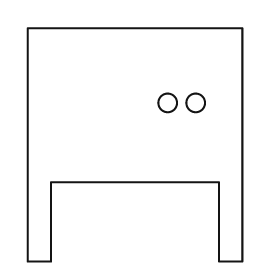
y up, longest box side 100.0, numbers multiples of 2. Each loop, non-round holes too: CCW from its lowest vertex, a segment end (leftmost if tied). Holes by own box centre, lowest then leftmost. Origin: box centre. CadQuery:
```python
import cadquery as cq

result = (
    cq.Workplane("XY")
    .moveTo(-46.0, -50.0)
    .lineTo(-36.0, -50.0)
    .lineTo(-36.0, -16.0)
    .lineTo(36.0, -16.0)
    .lineTo(36.0, -50.0)
    .lineTo(46.0, -50.0)
    .lineTo(46.0, 50.0)
    .lineTo(-46.0, 50.0)
    .close()
    .moveTo(14.0, 18.0)
    .circle(4.0)
    .moveTo(26.0, 18.0)
    .circle(4.0)
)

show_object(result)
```